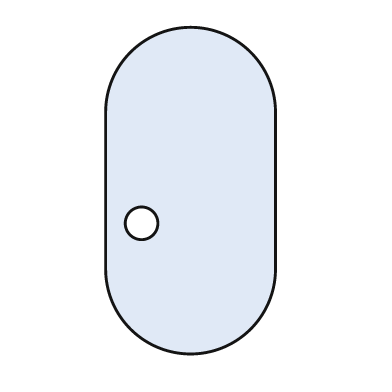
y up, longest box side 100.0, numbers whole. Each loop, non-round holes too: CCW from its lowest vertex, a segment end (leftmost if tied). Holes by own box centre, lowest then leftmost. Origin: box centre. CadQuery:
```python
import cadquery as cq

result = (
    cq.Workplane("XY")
    .moveTo(-26.0, -24.0)
    .threePointArc((0.0, -50.0), (26.0, -24.0))
    .lineTo(26.0, 24.0)
    .threePointArc((0.0, 50.0), (-26.0, 24.0))
    .close()
    .moveTo(-15.0, -10.0)
    .circle(5.0)
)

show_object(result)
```